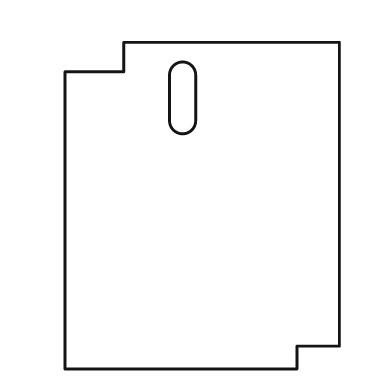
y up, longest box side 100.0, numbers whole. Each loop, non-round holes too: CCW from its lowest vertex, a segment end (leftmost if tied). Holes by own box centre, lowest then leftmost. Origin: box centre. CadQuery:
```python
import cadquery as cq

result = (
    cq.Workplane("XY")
    .moveTo(-42.0, -50.0)
    .lineTo(29.0, -50.0)
    .lineTo(29.0, -43.0)
    .lineTo(42.0, -43.0)
    .lineTo(42.0, 50.0)
    .lineTo(-24.0, 50.0)
    .lineTo(-24.0, 41.0)
    .lineTo(-42.0, 41.0)
    .close()
    .moveTo(-10.0, 26.0)
    .threePointArc((-6.0, 22.0), (-2.0, 26.0))
    .lineTo(-2.0, 40.0)
    .threePointArc((-6.0, 44.0), (-10.0, 40.0))
    .close()
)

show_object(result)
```